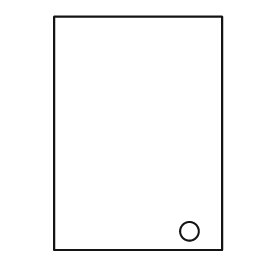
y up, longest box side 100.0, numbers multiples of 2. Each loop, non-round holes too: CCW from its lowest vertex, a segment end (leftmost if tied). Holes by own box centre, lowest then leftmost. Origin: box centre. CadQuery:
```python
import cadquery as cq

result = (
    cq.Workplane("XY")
    .moveTo(-36.0, -50.0)
    .lineTo(36.0, -50.0)
    .lineTo(36.0, 50.0)
    .lineTo(-36.0, 50.0)
    .close()
    .moveTo(22.0, -42.0)
    .circle(4.0)
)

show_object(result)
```